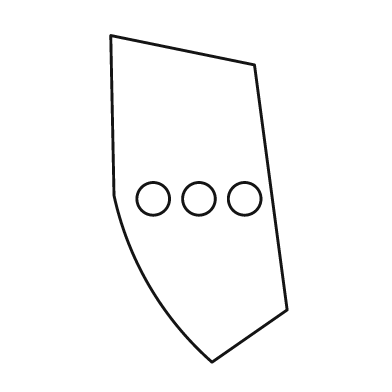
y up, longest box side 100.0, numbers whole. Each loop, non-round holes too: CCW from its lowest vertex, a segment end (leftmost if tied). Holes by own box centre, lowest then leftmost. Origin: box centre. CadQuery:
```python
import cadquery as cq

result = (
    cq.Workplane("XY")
    .moveTo(4.0, -50.0)
    .lineTo(27.0, -34.0)
    .lineTo(17.0, 41.0)
    .lineTo(-27.0, 50.0)
    .lineTo(-26.0, 1.0)
    .threePointArc((-15.0, -27.0), (4.0, -50.0))
    .close()
    .moveTo(-14.0, 0.0)
    .circle(5.0)
    .moveTo(0.0, 0.0)
    .circle(5.0)
    .moveTo(14.0, 0.0)
    .circle(5.0)
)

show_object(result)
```